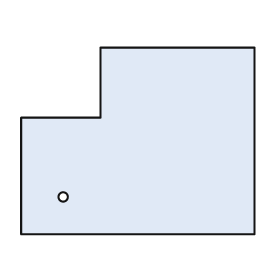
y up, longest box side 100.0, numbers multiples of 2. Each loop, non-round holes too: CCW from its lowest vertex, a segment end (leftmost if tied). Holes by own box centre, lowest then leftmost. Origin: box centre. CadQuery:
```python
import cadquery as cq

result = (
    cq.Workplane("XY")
    .moveTo(-50.0, -40.0)
    .lineTo(50.0, -40.0)
    .lineTo(50.0, 40.0)
    .lineTo(-16.0, 40.0)
    .lineTo(-16.0, 10.0)
    .lineTo(-50.0, 10.0)
    .close()
    .moveTo(-32.0, -24.0)
    .circle(2.0)
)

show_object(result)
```